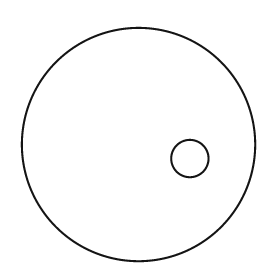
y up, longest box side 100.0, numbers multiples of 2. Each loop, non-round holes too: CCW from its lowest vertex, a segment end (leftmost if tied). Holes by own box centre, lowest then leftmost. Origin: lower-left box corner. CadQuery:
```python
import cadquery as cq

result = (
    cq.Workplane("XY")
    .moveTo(50.0, 50.0)
    .circle(50.0)
    .moveTo(72.0, 44.0)
    .circle(8.0)
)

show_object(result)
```